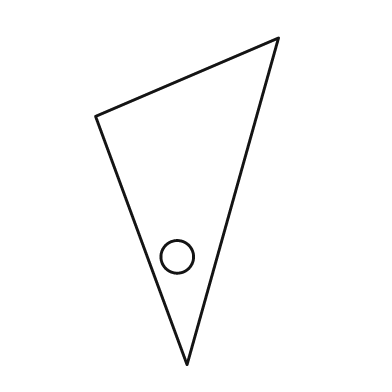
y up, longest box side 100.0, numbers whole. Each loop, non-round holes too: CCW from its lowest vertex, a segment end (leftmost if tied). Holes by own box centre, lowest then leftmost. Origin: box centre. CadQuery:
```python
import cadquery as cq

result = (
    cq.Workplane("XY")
    .moveTo(0.0, -50.0)
    .lineTo(28.0, 50.0)
    .lineTo(-28.0, 26.0)
    .close()
    .moveTo(-3.0, -17.0)
    .circle(5.0)
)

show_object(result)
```